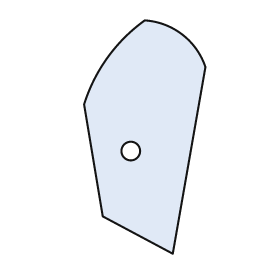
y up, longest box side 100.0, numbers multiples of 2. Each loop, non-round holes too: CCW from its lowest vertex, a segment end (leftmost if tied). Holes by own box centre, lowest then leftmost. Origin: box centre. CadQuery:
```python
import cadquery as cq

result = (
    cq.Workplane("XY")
    .moveTo(12.0, -50.0)
    .lineTo(26.0, 30.0)
    .threePointArc((16.0, 44.0), (0.0, 50.0))
    .threePointArc((-16.0, 34.0), (-26.0, 14.0))
    .lineTo(-18.0, -34.0)
    .close()
    .moveTo(-6.0, -6.0)
    .circle(4.0)
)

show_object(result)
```